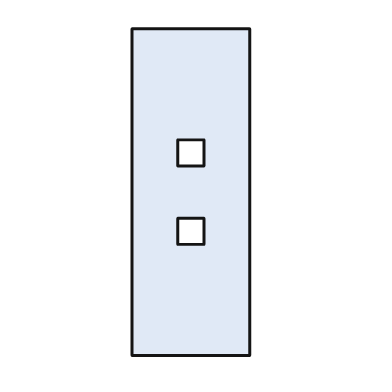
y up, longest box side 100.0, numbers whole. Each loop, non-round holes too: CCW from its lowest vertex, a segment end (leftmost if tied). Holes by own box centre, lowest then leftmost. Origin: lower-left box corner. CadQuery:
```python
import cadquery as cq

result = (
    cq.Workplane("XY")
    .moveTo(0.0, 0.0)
    .lineTo(36.0, 0.0)
    .lineTo(36.0, 100.0)
    .lineTo(0.0, 100.0)
    .close()
    .moveTo(14.0, 34.0)
    .lineTo(22.0, 34.0)
    .lineTo(22.0, 42.0)
    .lineTo(14.0, 42.0)
    .close()
    .moveTo(14.0, 58.0)
    .lineTo(22.0, 58.0)
    .lineTo(22.0, 66.0)
    .lineTo(14.0, 66.0)
    .close()
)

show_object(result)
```